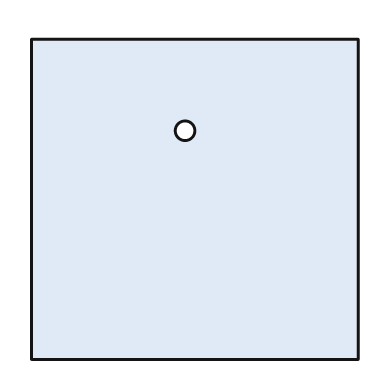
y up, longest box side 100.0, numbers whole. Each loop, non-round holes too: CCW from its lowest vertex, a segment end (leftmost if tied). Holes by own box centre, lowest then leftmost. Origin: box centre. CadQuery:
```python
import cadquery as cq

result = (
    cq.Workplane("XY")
    .moveTo(-50.0, -49.0)
    .lineTo(50.0, -49.0)
    .lineTo(50.0, 49.0)
    .lineTo(-50.0, 49.0)
    .close()
    .moveTo(-3.0, 21.0)
    .circle(3.0)
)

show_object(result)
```